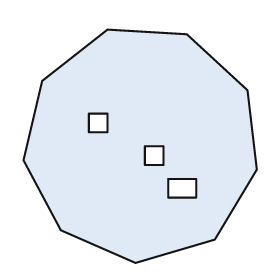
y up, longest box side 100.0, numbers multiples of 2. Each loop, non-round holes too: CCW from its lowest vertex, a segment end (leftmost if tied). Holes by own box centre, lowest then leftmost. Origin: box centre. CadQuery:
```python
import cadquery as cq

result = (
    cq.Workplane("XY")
    .moveTo(-2.0, -50.0)
    .lineTo(32.0, -40.0)
    .lineTo(50.0, -10.0)
    .lineTo(46.0, 24.0)
    .lineTo(20.0, 48.0)
    .lineTo(-14.0, 50.0)
    .lineTo(-42.0, 28.0)
    .lineTo(-50.0, -6.0)
    .lineTo(-34.0, -36.0)
    .close()
    .moveTo(12.0, -22.0)
    .lineTo(24.0, -22.0)
    .lineTo(24.0, -14.0)
    .lineTo(12.0, -14.0)
    .close()
    .moveTo(2.0, -8.0)
    .lineTo(10.0, -8.0)
    .lineTo(10.0, 0.0)
    .lineTo(2.0, 0.0)
    .close()
    .moveTo(-22.0, 6.0)
    .lineTo(-14.0, 6.0)
    .lineTo(-14.0, 14.0)
    .lineTo(-22.0, 14.0)
    .close()
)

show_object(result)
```